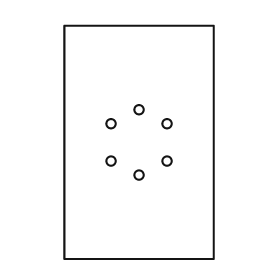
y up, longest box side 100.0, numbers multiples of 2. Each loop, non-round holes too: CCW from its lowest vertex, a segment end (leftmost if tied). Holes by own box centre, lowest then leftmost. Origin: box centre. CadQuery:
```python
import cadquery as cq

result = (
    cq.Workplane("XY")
    .moveTo(-32.0, -50.0)
    .lineTo(32.0, -50.0)
    .lineTo(32.0, 50.0)
    .lineTo(-32.0, 50.0)
    .close()
    .moveTo(0.0, -14.0)
    .circle(2.0)
    .moveTo(-12.0, -8.0)
    .circle(2.0)
    .moveTo(12.0, -8.0)
    .circle(2.0)
    .moveTo(-12.0, 8.0)
    .circle(2.0)
    .moveTo(12.0, 8.0)
    .circle(2.0)
    .moveTo(0.0, 14.0)
    .circle(2.0)
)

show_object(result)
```